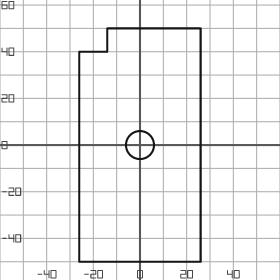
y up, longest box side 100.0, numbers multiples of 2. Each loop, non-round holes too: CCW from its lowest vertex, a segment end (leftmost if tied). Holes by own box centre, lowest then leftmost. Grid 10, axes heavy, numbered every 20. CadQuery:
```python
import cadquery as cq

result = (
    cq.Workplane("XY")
    .moveTo(-26.0, -50.0)
    .lineTo(26.0, -50.0)
    .lineTo(26.0, 50.0)
    .lineTo(-14.0, 50.0)
    .lineTo(-14.0, 40.0)
    .lineTo(-26.0, 40.0)
    .close()
    .moveTo(0.0, 0.0)
    .circle(6.0)
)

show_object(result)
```